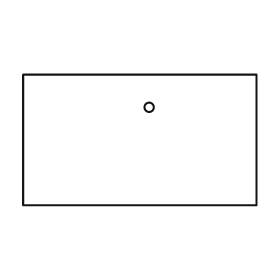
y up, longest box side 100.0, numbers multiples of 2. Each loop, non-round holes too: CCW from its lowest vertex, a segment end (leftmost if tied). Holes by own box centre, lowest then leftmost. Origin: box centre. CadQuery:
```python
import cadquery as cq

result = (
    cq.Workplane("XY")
    .moveTo(-50.0, -28.0)
    .lineTo(50.0, -28.0)
    .lineTo(50.0, 28.0)
    .lineTo(-50.0, 28.0)
    .close()
    .moveTo(4.0, 14.0)
    .circle(2.0)
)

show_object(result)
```